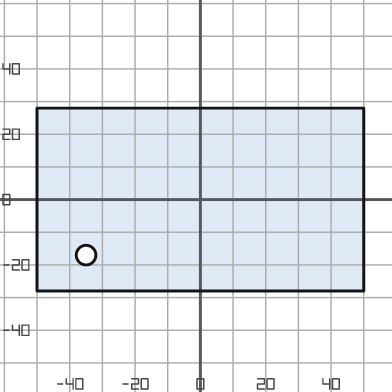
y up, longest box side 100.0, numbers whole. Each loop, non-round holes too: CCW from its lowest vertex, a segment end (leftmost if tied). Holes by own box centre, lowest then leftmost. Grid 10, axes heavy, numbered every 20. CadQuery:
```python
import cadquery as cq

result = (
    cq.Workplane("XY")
    .moveTo(-50.0, -28.0)
    .lineTo(50.0, -28.0)
    .lineTo(50.0, 28.0)
    .lineTo(-50.0, 28.0)
    .close()
    .moveTo(-35.0, -17.0)
    .circle(3.0)
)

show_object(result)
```